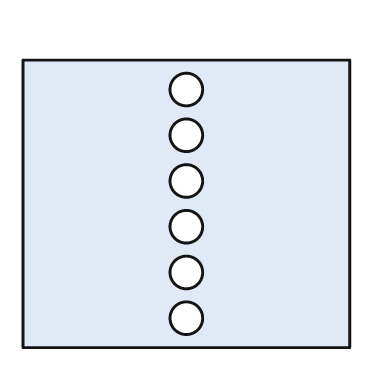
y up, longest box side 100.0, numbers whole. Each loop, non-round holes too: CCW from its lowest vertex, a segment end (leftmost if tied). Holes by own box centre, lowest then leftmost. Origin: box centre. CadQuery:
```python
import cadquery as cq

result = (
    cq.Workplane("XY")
    .moveTo(-50.0, -44.0)
    .lineTo(50.0, -44.0)
    .lineTo(50.0, 44.0)
    .lineTo(-50.0, 44.0)
    .close()
    .moveTo(0.0, -35.0)
    .circle(5.0)
    .moveTo(0.0, -21.0)
    .circle(5.0)
    .moveTo(0.0, -7.0)
    .circle(5.0)
    .moveTo(0.0, 7.0)
    .circle(5.0)
    .moveTo(0.0, 21.0)
    .circle(5.0)
    .moveTo(0.0, 35.0)
    .circle(5.0)
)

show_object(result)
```